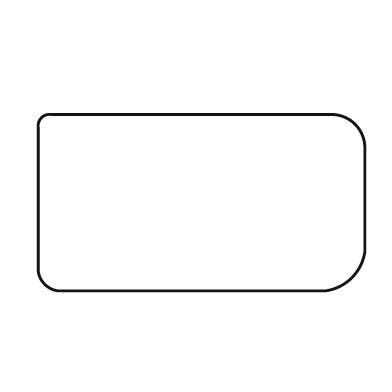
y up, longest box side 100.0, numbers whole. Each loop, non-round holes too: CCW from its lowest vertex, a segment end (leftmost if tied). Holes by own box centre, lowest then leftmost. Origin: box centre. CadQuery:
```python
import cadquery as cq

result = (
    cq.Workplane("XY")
    .moveTo(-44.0, -27.0)
    .lineTo(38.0, -27.0)
    .threePointArc((46.0, -23.0), (50.0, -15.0))
    .lineTo(50.0, 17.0)
    .threePointArc((47.0, 24.0), (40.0, 27.0))
    .lineTo(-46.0, 27.0)
    .threePointArc((-49.0, 26.0), (-50.0, 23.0))
    .lineTo(-50.0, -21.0)
    .threePointArc((-48.0, -25.0), (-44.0, -27.0))
    .close()
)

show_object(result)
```